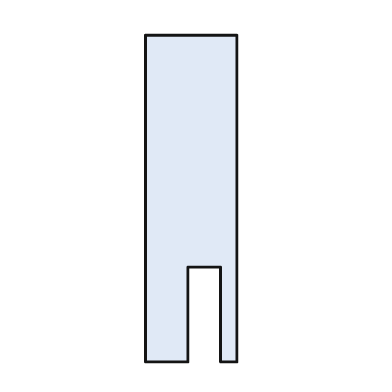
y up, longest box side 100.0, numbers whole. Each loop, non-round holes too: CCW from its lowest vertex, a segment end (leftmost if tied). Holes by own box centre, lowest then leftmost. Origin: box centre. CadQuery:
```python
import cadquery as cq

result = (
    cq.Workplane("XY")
    .moveTo(-14.0, -50.0)
    .lineTo(-1.0, -50.0)
    .lineTo(-1.0, -21.0)
    .lineTo(9.0, -21.0)
    .lineTo(9.0, -50.0)
    .lineTo(14.0, -50.0)
    .lineTo(14.0, 50.0)
    .lineTo(-14.0, 50.0)
    .close()
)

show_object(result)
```